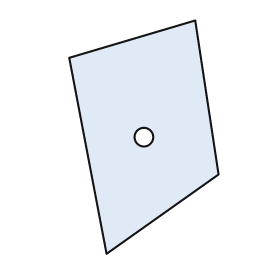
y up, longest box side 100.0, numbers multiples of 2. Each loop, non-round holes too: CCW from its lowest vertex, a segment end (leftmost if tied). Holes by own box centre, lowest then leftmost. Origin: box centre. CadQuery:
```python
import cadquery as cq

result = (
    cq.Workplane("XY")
    .moveTo(-16.0, -50.0)
    .lineTo(32.0, -16.0)
    .lineTo(22.0, 50.0)
    .lineTo(-32.0, 34.0)
    .close()
    .moveTo(0.0, 0.0)
    .circle(4.0)
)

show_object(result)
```